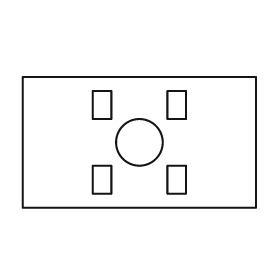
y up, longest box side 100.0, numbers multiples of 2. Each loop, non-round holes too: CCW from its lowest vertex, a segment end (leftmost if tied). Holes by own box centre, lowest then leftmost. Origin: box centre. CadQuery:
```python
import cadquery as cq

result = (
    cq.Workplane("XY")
    .moveTo(-50.0, -28.0)
    .lineTo(50.0, -28.0)
    .lineTo(50.0, 28.0)
    .lineTo(-50.0, 28.0)
    .close()
    .moveTo(-20.0, -22.0)
    .lineTo(-12.0, -22.0)
    .lineTo(-12.0, -10.0)
    .lineTo(-20.0, -10.0)
    .close()
    .moveTo(12.0, -22.0)
    .lineTo(20.0, -22.0)
    .lineTo(20.0, -10.0)
    .lineTo(12.0, -10.0)
    .close()
    .moveTo(0.0, 0.0)
    .circle(10.0)
    .moveTo(-20.0, 10.0)
    .lineTo(-12.0, 10.0)
    .lineTo(-12.0, 22.0)
    .lineTo(-20.0, 22.0)
    .close()
    .moveTo(12.0, 10.0)
    .lineTo(20.0, 10.0)
    .lineTo(20.0, 22.0)
    .lineTo(12.0, 22.0)
    .close()
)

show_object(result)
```